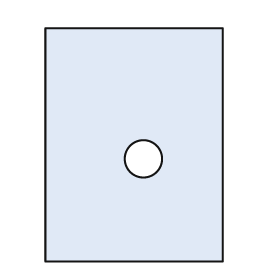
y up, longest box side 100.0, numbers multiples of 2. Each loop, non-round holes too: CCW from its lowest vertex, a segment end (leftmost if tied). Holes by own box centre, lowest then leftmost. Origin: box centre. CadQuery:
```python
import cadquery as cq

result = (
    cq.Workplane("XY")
    .moveTo(-38.0, -50.0)
    .lineTo(38.0, -50.0)
    .lineTo(38.0, 50.0)
    .lineTo(-38.0, 50.0)
    .close()
    .moveTo(4.0, -6.0)
    .circle(8.0)
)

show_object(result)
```